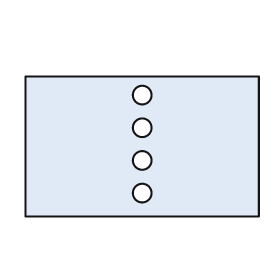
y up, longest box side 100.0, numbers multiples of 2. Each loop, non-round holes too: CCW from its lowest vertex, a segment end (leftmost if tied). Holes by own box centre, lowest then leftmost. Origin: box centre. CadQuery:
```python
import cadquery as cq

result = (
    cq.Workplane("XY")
    .moveTo(-50.0, -30.0)
    .lineTo(50.0, -30.0)
    .lineTo(50.0, 30.0)
    .lineTo(-50.0, 30.0)
    .close()
    .moveTo(0.0, -20.0)
    .circle(4.0)
    .moveTo(0.0, -6.0)
    .circle(4.0)
    .moveTo(0.0, 8.0)
    .circle(4.0)
    .moveTo(0.0, 22.0)
    .circle(4.0)
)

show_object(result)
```